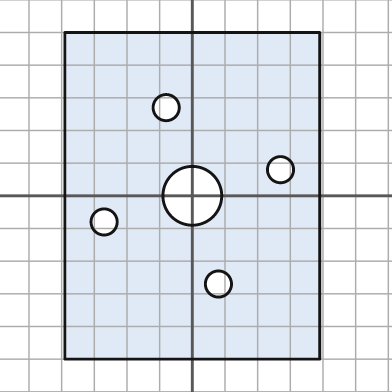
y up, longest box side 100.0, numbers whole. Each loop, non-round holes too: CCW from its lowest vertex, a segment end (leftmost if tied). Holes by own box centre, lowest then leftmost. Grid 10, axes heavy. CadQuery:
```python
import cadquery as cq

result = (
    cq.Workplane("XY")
    .moveTo(-39.0, -50.0)
    .lineTo(39.0, -50.0)
    .lineTo(39.0, 50.0)
    .lineTo(-39.0, 50.0)
    .close()
    .moveTo(8.0, -27.0)
    .circle(4.0)
    .moveTo(-27.0, -8.0)
    .circle(4.0)
    .moveTo(0.0, 0.0)
    .circle(9.0)
    .moveTo(27.0, 8.0)
    .circle(4.0)
    .moveTo(-8.0, 27.0)
    .circle(4.0)
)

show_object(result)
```